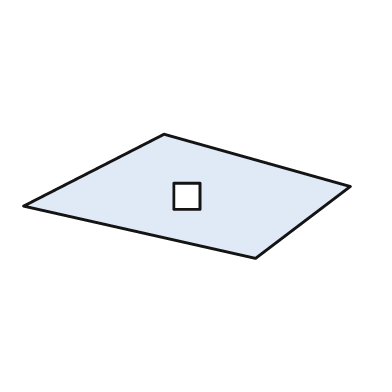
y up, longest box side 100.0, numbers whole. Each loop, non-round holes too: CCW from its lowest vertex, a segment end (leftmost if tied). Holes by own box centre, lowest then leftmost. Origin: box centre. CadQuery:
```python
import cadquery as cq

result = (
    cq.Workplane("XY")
    .moveTo(21.0, -19.0)
    .lineTo(50.0, 3.0)
    .lineTo(-7.0, 19.0)
    .lineTo(-50.0, -3.0)
    .close()
    .moveTo(-4.0, -4.0)
    .lineTo(4.0, -4.0)
    .lineTo(4.0, 4.0)
    .lineTo(-4.0, 4.0)
    .close()
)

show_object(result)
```